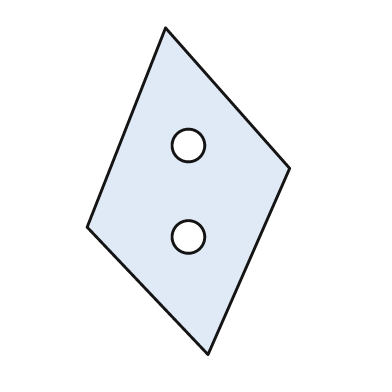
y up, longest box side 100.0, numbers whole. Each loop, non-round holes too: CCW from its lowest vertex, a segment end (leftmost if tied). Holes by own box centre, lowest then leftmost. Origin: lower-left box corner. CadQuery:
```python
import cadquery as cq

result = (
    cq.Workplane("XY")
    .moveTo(37.0, 0.0)
    .lineTo(62.0, 57.0)
    .lineTo(24.0, 100.0)
    .lineTo(0.0, 39.0)
    .close()
    .moveTo(31.0, 36.0)
    .circle(5.0)
    .moveTo(31.0, 64.0)
    .circle(5.0)
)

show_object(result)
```